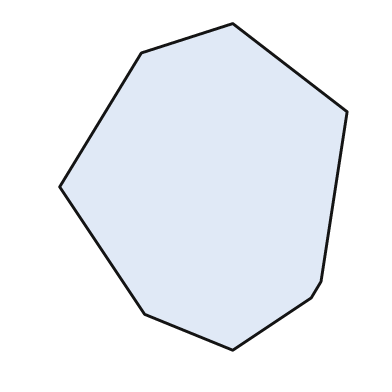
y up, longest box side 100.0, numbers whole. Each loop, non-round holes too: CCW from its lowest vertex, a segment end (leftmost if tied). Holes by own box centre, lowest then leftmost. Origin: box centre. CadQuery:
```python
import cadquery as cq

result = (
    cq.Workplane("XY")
    .moveTo(9.0, -50.0)
    .lineTo(33.0, -34.0)
    .lineTo(36.0, -29.0)
    .lineTo(44.0, 23.0)
    .lineTo(9.0, 50.0)
    .lineTo(-19.0, 41.0)
    .lineTo(-44.0, 0.0)
    .lineTo(-18.0, -39.0)
    .close()
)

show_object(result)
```